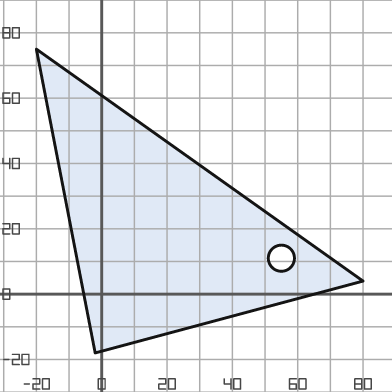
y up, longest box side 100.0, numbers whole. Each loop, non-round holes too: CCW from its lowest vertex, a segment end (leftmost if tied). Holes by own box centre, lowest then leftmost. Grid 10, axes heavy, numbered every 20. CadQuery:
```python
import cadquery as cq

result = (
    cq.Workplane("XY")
    .moveTo(-2.0, -18.0)
    .lineTo(80.0, 4.0)
    .lineTo(-20.0, 75.0)
    .close()
    .moveTo(55.0, 11.0)
    .circle(4.0)
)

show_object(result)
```